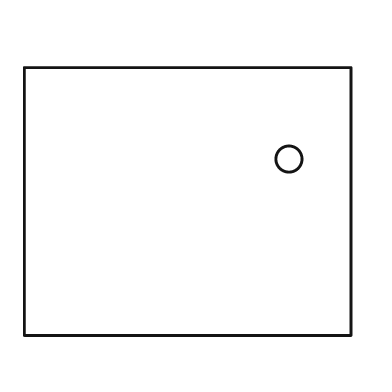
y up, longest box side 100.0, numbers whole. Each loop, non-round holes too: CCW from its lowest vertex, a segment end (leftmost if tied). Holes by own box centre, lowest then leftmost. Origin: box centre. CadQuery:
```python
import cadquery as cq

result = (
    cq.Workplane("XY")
    .moveTo(-50.0, -41.0)
    .lineTo(50.0, -41.0)
    .lineTo(50.0, 41.0)
    .lineTo(-50.0, 41.0)
    .close()
    .moveTo(31.0, 13.0)
    .circle(4.0)
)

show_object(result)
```